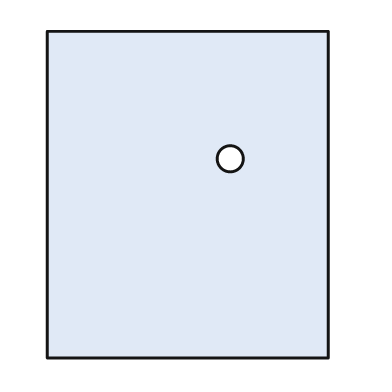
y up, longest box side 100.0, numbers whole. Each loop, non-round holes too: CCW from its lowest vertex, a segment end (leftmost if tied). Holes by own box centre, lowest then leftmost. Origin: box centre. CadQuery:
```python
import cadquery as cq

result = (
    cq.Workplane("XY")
    .moveTo(-43.0, -50.0)
    .lineTo(43.0, -50.0)
    .lineTo(43.0, 50.0)
    .lineTo(-43.0, 50.0)
    .close()
    .moveTo(13.0, 11.0)
    .circle(4.0)
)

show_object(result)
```